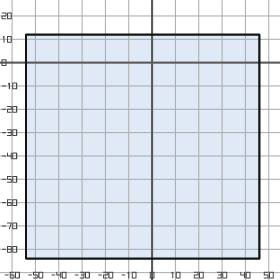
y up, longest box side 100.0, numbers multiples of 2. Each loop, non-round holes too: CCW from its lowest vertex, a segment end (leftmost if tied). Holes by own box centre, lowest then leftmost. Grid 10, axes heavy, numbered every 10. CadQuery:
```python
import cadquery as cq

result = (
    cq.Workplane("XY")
    .moveTo(-54.0, -84.0)
    .lineTo(46.0, -84.0)
    .lineTo(46.0, 12.0)
    .lineTo(-54.0, 12.0)
    .close()
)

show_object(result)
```